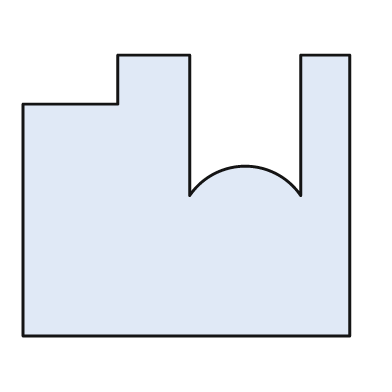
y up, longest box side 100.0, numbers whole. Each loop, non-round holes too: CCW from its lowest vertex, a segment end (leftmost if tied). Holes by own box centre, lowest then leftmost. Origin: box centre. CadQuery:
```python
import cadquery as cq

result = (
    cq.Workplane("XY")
    .moveTo(-50.0, -43.0)
    .lineTo(50.0, -43.0)
    .lineTo(50.0, 43.0)
    .lineTo(35.0, 43.0)
    .lineTo(35.0, 0.0)
    .threePointArc((18.0, 9.0), (1.0, 0.0))
    .lineTo(1.0, 43.0)
    .lineTo(-21.0, 43.0)
    .lineTo(-21.0, 28.0)
    .lineTo(-50.0, 28.0)
    .close()
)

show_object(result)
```